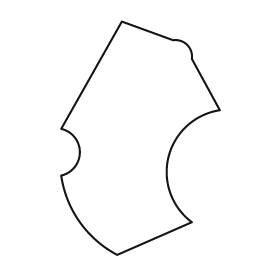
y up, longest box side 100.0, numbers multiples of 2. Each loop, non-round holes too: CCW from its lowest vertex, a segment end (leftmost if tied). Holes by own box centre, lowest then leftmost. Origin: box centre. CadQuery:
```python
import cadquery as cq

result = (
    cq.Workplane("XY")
    .moveTo(-10.0, -50.0)
    .lineTo(22.0, -36.0)
    .threePointArc((12.0, -8.0), (34.0, 12.0))
    .lineTo(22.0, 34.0)
    .threePointArc((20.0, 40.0), (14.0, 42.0))
    .lineTo(-8.0, 50.0)
    .lineTo(-34.0, 4.0)
    .threePointArc((-26.0, -6.0), (-34.0, -16.0))
    .threePointArc((-26.0, -36.0), (-10.0, -50.0))
    .close()
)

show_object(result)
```